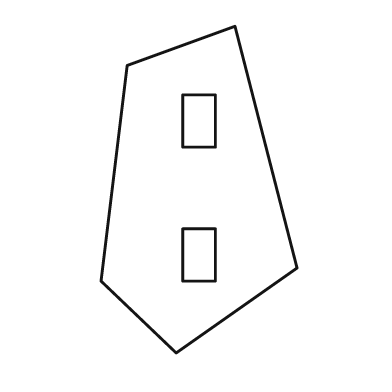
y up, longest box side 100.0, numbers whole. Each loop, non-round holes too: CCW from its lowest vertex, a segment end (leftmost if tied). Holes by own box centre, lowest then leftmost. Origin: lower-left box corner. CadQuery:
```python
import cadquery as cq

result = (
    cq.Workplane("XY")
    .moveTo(23.0, 0.0)
    .lineTo(60.0, 26.0)
    .lineTo(41.0, 100.0)
    .lineTo(8.0, 88.0)
    .lineTo(0.0, 22.0)
    .close()
    .moveTo(25.0, 22.0)
    .lineTo(35.0, 22.0)
    .lineTo(35.0, 38.0)
    .lineTo(25.0, 38.0)
    .close()
    .moveTo(25.0, 63.0)
    .lineTo(35.0, 63.0)
    .lineTo(35.0, 79.0)
    .lineTo(25.0, 79.0)
    .close()
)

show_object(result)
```